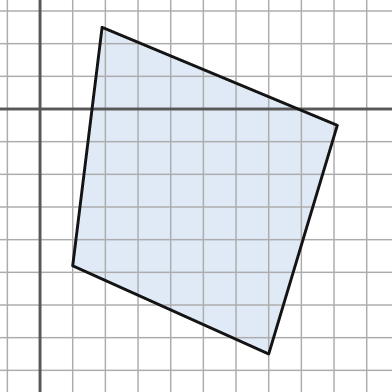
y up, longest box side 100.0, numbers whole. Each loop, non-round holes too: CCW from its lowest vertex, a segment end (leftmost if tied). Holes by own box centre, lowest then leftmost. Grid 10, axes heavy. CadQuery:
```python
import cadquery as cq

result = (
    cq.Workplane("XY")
    .moveTo(70.0, -75.0)
    .lineTo(91.0, -5.0)
    .lineTo(19.0, 25.0)
    .lineTo(10.0, -48.0)
    .close()
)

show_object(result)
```